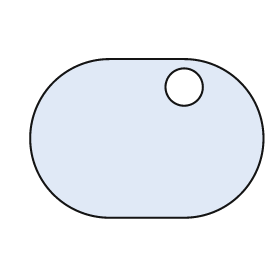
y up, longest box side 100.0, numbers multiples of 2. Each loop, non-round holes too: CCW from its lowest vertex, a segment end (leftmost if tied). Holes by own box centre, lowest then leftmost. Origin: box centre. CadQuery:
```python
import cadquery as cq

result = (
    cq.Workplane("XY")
    .moveTo(-16.0, -34.0)
    .lineTo(16.0, -34.0)
    .threePointArc((50.0, 0.0), (16.0, 34.0))
    .lineTo(-16.0, 34.0)
    .threePointArc((-50.0, 0.0), (-16.0, -34.0))
    .close()
    .moveTo(16.0, 22.0)
    .circle(8.0)
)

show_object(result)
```